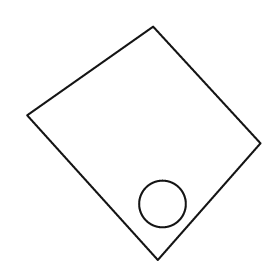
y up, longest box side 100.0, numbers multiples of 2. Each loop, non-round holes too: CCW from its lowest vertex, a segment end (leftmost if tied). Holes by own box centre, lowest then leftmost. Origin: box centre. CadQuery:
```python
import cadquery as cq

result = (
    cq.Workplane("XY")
    .moveTo(6.0, -50.0)
    .lineTo(50.0, 0.0)
    .lineTo(4.0, 50.0)
    .lineTo(-50.0, 12.0)
    .close()
    .moveTo(8.0, -26.0)
    .circle(10.0)
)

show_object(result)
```